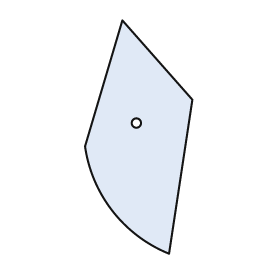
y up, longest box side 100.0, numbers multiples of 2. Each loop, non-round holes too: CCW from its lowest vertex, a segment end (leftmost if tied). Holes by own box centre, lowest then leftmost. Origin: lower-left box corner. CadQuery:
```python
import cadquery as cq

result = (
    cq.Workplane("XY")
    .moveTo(36.0, 0.0)
    .lineTo(46.0, 66.0)
    .lineTo(16.0, 100.0)
    .lineTo(0.0, 46.0)
    .threePointArc((12.0, 18.0), (36.0, 0.0))
    .close()
    .moveTo(22.0, 56.0)
    .circle(2.0)
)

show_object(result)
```